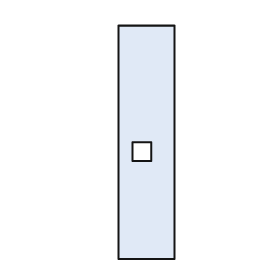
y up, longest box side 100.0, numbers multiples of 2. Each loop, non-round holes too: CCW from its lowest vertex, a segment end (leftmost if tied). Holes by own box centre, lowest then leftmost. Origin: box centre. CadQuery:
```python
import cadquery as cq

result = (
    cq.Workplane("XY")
    .moveTo(-12.0, -50.0)
    .lineTo(12.0, -50.0)
    .lineTo(12.0, 50.0)
    .lineTo(-12.0, 50.0)
    .close()
    .moveTo(-6.0, -8.0)
    .lineTo(2.0, -8.0)
    .lineTo(2.0, 0.0)
    .lineTo(-6.0, 0.0)
    .close()
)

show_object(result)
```